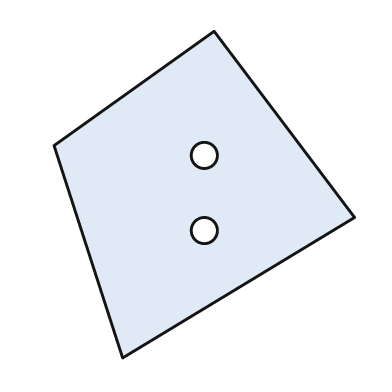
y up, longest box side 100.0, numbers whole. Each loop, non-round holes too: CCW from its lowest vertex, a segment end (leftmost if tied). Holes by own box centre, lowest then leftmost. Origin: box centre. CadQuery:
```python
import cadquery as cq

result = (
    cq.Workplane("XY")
    .moveTo(-25.0, -50.0)
    .lineTo(46.0, -7.0)
    .lineTo(3.0, 50.0)
    .lineTo(-46.0, 15.0)
    .close()
    .moveTo(0.0, -11.0)
    .circle(4.0)
    .moveTo(0.0, 12.0)
    .circle(4.0)
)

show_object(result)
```